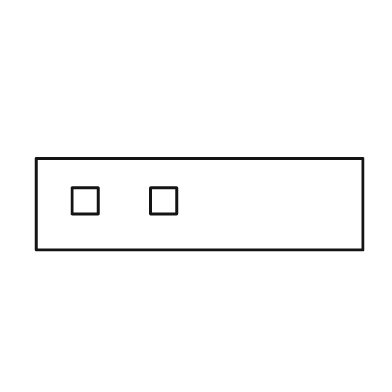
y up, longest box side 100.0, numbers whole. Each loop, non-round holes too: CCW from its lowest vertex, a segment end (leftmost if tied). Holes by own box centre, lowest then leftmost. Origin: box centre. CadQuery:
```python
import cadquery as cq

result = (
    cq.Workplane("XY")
    .moveTo(-50.0, -14.0)
    .lineTo(50.0, -14.0)
    .lineTo(50.0, 14.0)
    .lineTo(-50.0, 14.0)
    .close()
    .moveTo(-39.0, -3.0)
    .lineTo(-31.0, -3.0)
    .lineTo(-31.0, 5.0)
    .lineTo(-39.0, 5.0)
    .close()
    .moveTo(-15.0, -3.0)
    .lineTo(-7.0, -3.0)
    .lineTo(-7.0, 5.0)
    .lineTo(-15.0, 5.0)
    .close()
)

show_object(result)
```